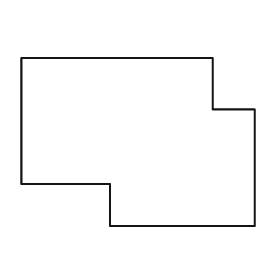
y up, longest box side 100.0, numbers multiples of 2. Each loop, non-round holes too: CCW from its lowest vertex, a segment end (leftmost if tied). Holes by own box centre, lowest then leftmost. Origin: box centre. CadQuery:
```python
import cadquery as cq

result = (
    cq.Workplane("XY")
    .moveTo(-12.0, -36.0)
    .lineTo(50.0, -36.0)
    .lineTo(50.0, 14.0)
    .lineTo(32.0, 14.0)
    .lineTo(32.0, 36.0)
    .lineTo(-50.0, 36.0)
    .lineTo(-50.0, -18.0)
    .lineTo(-12.0, -18.0)
    .close()
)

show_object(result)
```